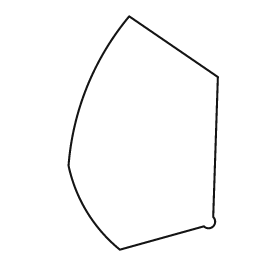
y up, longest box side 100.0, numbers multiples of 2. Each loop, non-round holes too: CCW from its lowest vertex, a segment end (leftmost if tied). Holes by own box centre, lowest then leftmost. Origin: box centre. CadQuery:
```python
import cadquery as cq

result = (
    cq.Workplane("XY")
    .moveTo(-10.0, -50.0)
    .lineTo(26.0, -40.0)
    .threePointArc((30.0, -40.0), (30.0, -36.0))
    .lineTo(32.0, 24.0)
    .lineTo(-6.0, 50.0)
    .threePointArc((-24.0, 20.0), (-32.0, -14.0))
    .threePointArc((-24.0, -34.0), (-10.0, -50.0))
    .close()
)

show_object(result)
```